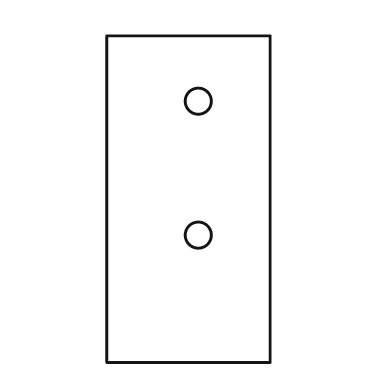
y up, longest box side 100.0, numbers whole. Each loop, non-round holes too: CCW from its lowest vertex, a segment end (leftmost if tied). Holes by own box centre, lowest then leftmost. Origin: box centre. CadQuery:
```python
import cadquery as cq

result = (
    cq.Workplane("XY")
    .moveTo(-25.0, -50.0)
    .lineTo(25.0, -50.0)
    .lineTo(25.0, 50.0)
    .lineTo(-25.0, 50.0)
    .close()
    .moveTo(3.0, -11.0)
    .circle(4.0)
    .moveTo(3.0, 30.0)
    .circle(4.0)
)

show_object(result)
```